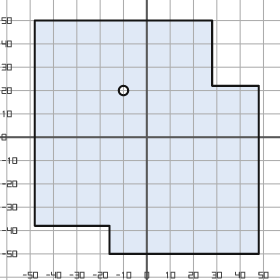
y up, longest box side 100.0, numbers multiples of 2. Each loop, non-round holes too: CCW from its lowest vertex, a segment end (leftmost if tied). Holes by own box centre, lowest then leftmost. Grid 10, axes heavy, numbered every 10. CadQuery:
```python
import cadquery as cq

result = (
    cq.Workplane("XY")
    .moveTo(-16.0, -50.0)
    .lineTo(48.0, -50.0)
    .lineTo(48.0, 22.0)
    .lineTo(28.0, 22.0)
    .lineTo(28.0, 50.0)
    .lineTo(-48.0, 50.0)
    .lineTo(-48.0, -38.0)
    .lineTo(-16.0, -38.0)
    .close()
    .moveTo(-10.0, 20.0)
    .circle(2.0)
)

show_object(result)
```